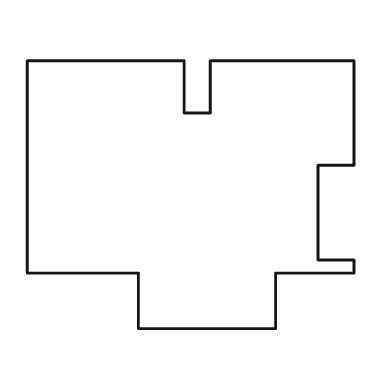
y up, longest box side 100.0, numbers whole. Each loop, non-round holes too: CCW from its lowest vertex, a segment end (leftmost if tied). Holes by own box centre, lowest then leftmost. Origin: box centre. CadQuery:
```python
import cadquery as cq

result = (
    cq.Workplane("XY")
    .moveTo(-16.0, -41.0)
    .lineTo(26.0, -41.0)
    .lineTo(26.0, -24.0)
    .lineTo(50.0, -24.0)
    .lineTo(50.0, -20.0)
    .lineTo(39.0, -20.0)
    .lineTo(39.0, 9.0)
    .lineTo(50.0, 9.0)
    .lineTo(50.0, 41.0)
    .lineTo(6.0, 41.0)
    .lineTo(6.0, 25.0)
    .lineTo(-2.0, 25.0)
    .lineTo(-2.0, 41.0)
    .lineTo(-50.0, 41.0)
    .lineTo(-50.0, -24.0)
    .lineTo(-16.0, -24.0)
    .close()
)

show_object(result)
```